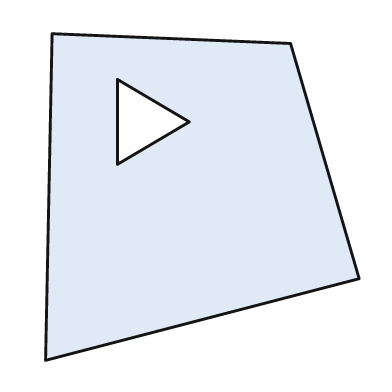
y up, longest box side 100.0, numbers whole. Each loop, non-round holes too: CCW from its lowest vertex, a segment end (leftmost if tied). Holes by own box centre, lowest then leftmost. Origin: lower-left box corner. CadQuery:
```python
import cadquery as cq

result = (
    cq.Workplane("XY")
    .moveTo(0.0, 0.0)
    .lineTo(96.0, 25.0)
    .lineTo(75.0, 97.0)
    .lineTo(2.0, 100.0)
    .close()
    .moveTo(22.0, 60.0)
    .lineTo(44.0, 73.0)
    .lineTo(22.0, 86.0)
    .close()
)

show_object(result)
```